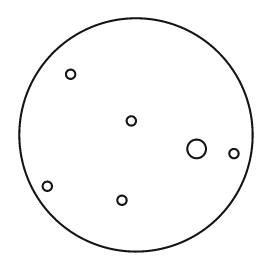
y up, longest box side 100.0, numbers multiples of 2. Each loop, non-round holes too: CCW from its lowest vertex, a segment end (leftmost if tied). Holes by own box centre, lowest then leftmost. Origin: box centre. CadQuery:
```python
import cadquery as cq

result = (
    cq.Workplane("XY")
    .moveTo(0.0, 0.0)
    .circle(50.0)
    .moveTo(-6.0, -28.0)
    .circle(2.0)
    .moveTo(-38.0, -22.0)
    .circle(2.0)
    .moveTo(42.0, -8.0)
    .circle(2.0)
    .moveTo(26.0, -6.0)
    .circle(4.0)
    .moveTo(-2.0, 6.0)
    .circle(2.0)
    .moveTo(-28.0, 26.0)
    .circle(2.0)
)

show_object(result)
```